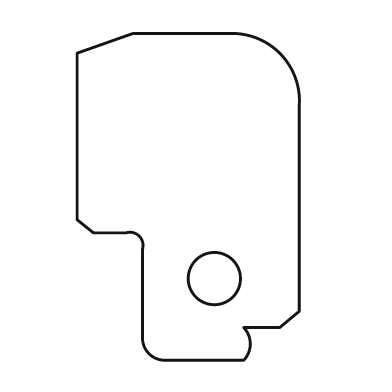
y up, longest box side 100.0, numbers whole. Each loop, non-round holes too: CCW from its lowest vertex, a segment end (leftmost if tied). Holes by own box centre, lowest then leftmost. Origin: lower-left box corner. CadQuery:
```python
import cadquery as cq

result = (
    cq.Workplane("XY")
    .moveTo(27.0, 0.0)
    .lineTo(51.0, 0.0)
    .threePointArc((53.0, 5.0), (51.0, 10.0))
    .lineTo(62.0, 10.0)
    .lineTo(68.0, 15.0)
    .lineTo(68.0, 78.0)
    .threePointArc((62.0, 94.0), (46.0, 100.0))
    .lineTo(17.0, 100.0)
    .lineTo(0.0, 94.0)
    .lineTo(0.0, 43.0)
    .lineTo(5.0, 39.0)
    .lineTo(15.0, 39.0)
    .threePointArc((19.0, 38.0), (20.0, 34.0))
    .lineTo(20.0, 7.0)
    .threePointArc((22.0, 2.0), (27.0, 0.0))
    .close()
    .moveTo(42.0, 25.0)
    .circle(8.0)
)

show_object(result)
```